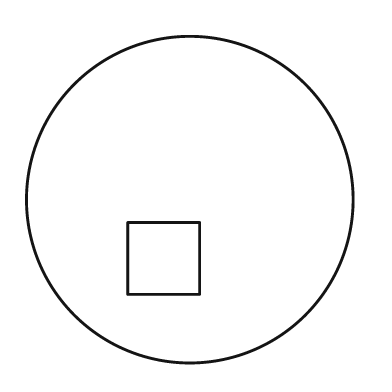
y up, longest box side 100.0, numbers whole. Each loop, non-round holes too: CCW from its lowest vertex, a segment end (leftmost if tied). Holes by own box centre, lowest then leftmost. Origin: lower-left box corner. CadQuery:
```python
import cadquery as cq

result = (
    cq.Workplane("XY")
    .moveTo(50.0, 50.0)
    .circle(50.0)
    .moveTo(31.0, 21.0)
    .lineTo(53.0, 21.0)
    .lineTo(53.0, 43.0)
    .lineTo(31.0, 43.0)
    .close()
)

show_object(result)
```